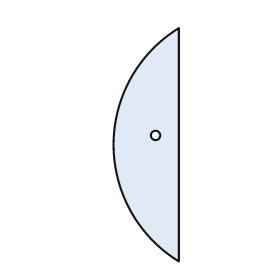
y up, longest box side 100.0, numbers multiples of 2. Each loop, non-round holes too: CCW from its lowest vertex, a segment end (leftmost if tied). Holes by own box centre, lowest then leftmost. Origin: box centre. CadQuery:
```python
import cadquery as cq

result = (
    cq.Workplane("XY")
    .moveTo(14.0, -50.0)
    .lineTo(14.0, 50.0)
    .threePointArc((-14.0, 0.0), (14.0, -50.0))
    .close()
    .moveTo(4.0, 4.0)
    .circle(2.0)
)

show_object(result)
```